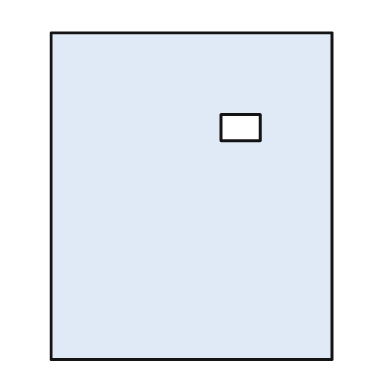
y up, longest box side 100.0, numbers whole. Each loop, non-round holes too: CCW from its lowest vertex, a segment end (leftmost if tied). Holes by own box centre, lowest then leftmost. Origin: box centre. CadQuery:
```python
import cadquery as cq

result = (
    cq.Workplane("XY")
    .moveTo(-43.0, -50.0)
    .lineTo(43.0, -50.0)
    .lineTo(43.0, 50.0)
    .lineTo(-43.0, 50.0)
    .close()
    .moveTo(9.0, 17.0)
    .lineTo(21.0, 17.0)
    .lineTo(21.0, 25.0)
    .lineTo(9.0, 25.0)
    .close()
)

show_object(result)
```